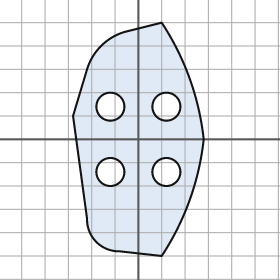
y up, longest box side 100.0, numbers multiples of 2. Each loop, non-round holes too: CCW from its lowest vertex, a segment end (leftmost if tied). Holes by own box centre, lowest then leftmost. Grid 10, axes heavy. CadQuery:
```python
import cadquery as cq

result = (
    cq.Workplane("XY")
    .moveTo(10.0, -50.0)
    .threePointArc((22.0, -26.0), (28.0, 0.0))
    .threePointArc((22.0, 26.0), (10.0, 50.0))
    .lineTo(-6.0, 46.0)
    .threePointArc((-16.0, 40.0), (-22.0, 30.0))
    .lineTo(-28.0, 10.0)
    .lineTo(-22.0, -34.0)
    .threePointArc((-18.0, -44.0), (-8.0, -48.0))
    .close()
    .moveTo(-12.0, -14.0)
    .circle(6.0)
    .moveTo(12.0, -14.0)
    .circle(6.0)
    .moveTo(-12.0, 14.0)
    .circle(6.0)
    .moveTo(12.0, 14.0)
    .circle(6.0)
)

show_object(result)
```